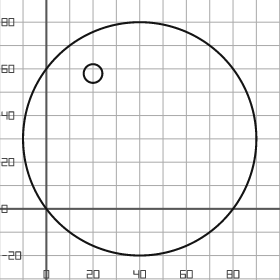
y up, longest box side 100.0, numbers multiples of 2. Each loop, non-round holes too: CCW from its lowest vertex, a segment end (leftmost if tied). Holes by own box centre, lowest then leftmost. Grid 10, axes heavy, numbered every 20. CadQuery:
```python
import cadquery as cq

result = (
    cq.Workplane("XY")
    .moveTo(40.0, 30.0)
    .circle(50.0)
    .moveTo(20.0, 58.0)
    .circle(4.0)
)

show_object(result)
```